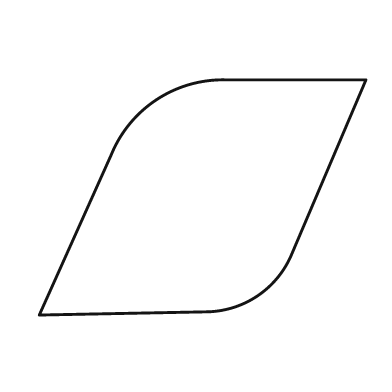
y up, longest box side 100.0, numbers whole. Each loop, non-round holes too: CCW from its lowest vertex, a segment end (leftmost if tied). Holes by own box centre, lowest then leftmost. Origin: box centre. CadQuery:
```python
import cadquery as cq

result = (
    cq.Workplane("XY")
    .moveTo(-50.0, -36.0)
    .lineTo(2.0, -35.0)
    .threePointArc((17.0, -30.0), (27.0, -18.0))
    .lineTo(50.0, 36.0)
    .lineTo(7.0, 36.0)
    .threePointArc((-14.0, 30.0), (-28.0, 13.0))
    .close()
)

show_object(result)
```